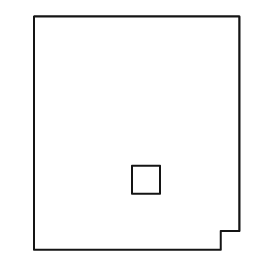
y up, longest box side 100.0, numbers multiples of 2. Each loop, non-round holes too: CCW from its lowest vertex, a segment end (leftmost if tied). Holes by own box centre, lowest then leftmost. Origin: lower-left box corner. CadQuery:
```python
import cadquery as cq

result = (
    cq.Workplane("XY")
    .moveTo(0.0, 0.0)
    .lineTo(80.0, 0.0)
    .lineTo(80.0, 8.0)
    .lineTo(88.0, 8.0)
    .lineTo(88.0, 100.0)
    .lineTo(0.0, 100.0)
    .close()
    .moveTo(42.0, 24.0)
    .lineTo(54.0, 24.0)
    .lineTo(54.0, 36.0)
    .lineTo(42.0, 36.0)
    .close()
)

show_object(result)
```